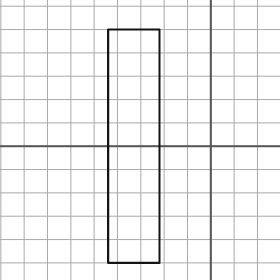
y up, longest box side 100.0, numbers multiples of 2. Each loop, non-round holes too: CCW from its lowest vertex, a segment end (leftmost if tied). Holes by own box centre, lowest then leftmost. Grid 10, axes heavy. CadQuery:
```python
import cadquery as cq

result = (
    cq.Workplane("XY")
    .moveTo(-44.0, -50.0)
    .lineTo(-22.0, -50.0)
    .lineTo(-22.0, 50.0)
    .lineTo(-44.0, 50.0)
    .close()
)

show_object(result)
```